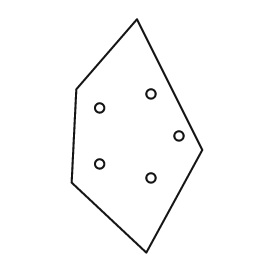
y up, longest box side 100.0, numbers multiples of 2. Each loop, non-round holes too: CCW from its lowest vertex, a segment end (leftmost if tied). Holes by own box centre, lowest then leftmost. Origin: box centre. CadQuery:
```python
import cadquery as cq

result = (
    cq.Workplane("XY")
    .moveTo(4.0, -50.0)
    .lineTo(28.0, -6.0)
    .lineTo(0.0, 50.0)
    .lineTo(-26.0, 20.0)
    .lineTo(-28.0, -20.0)
    .close()
    .moveTo(6.0, -18.0)
    .circle(2.0)
    .moveTo(-16.0, -12.0)
    .circle(2.0)
    .moveTo(18.0, 0.0)
    .circle(2.0)
    .moveTo(-16.0, 12.0)
    .circle(2.0)
    .moveTo(6.0, 18.0)
    .circle(2.0)
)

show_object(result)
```